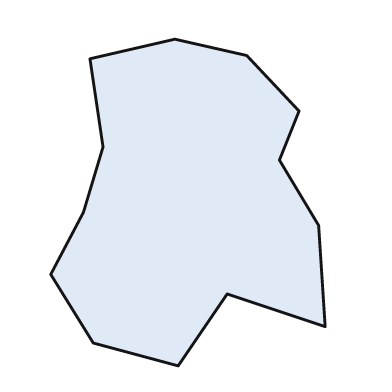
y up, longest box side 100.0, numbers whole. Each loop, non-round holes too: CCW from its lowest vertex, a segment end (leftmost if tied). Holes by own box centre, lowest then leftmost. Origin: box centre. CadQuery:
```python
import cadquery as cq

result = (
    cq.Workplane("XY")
    .moveTo(-3.0, -50.0)
    .lineTo(12.0, -28.0)
    .lineTo(42.0, -38.0)
    .lineTo(40.0, -7.0)
    .lineTo(28.0, 13.0)
    .lineTo(34.0, 28.0)
    .lineTo(18.0, 45.0)
    .lineTo(-4.0, 50.0)
    .lineTo(-30.0, 44.0)
    .lineTo(-26.0, 17.0)
    .lineTo(-32.0, -3.0)
    .lineTo(-42.0, -22.0)
    .lineTo(-29.0, -43.0)
    .close()
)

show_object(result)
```